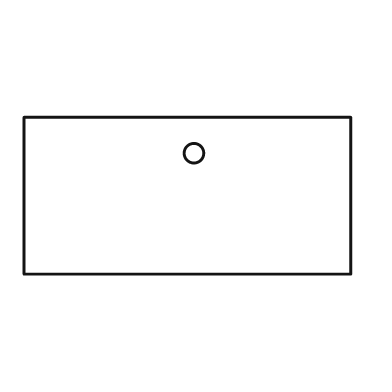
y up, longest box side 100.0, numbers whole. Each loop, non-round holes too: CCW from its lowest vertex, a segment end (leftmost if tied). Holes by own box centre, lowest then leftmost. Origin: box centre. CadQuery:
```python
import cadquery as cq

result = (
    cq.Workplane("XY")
    .moveTo(-50.0, -24.0)
    .lineTo(50.0, -24.0)
    .lineTo(50.0, 24.0)
    .lineTo(-50.0, 24.0)
    .close()
    .moveTo(2.0, 13.0)
    .circle(3.0)
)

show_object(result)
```